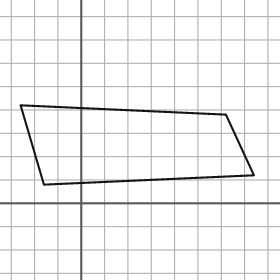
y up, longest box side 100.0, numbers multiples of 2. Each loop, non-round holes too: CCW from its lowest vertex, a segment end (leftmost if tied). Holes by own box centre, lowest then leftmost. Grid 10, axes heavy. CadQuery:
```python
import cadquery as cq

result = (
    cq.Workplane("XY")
    .moveTo(-16.0, 8.0)
    .lineTo(74.0, 12.0)
    .lineTo(62.0, 38.0)
    .lineTo(-26.0, 42.0)
    .close()
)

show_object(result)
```